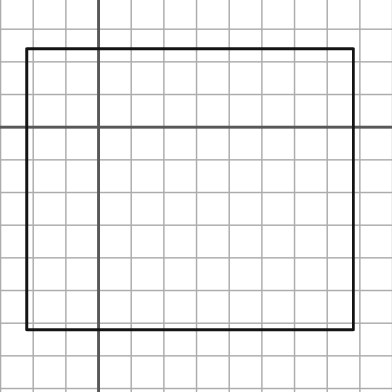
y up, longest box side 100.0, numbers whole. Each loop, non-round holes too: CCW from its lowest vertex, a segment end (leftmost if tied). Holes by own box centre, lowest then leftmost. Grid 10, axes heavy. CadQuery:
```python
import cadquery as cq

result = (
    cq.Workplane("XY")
    .moveTo(-22.0, -62.0)
    .lineTo(78.0, -62.0)
    .lineTo(78.0, 24.0)
    .lineTo(-22.0, 24.0)
    .close()
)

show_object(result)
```